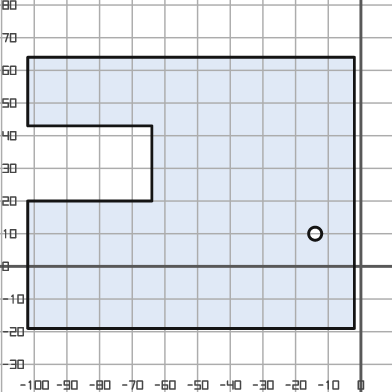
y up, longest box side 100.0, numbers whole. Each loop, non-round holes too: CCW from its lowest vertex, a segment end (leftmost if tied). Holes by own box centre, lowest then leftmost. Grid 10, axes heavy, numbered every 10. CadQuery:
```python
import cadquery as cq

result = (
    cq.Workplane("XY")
    .moveTo(-102.0, -19.0)
    .lineTo(-2.0, -19.0)
    .lineTo(-2.0, 64.0)
    .lineTo(-102.0, 64.0)
    .lineTo(-102.0, 43.0)
    .lineTo(-64.0, 43.0)
    .lineTo(-64.0, 20.0)
    .lineTo(-102.0, 20.0)
    .close()
    .moveTo(-14.0, 10.0)
    .circle(2.0)
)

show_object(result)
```